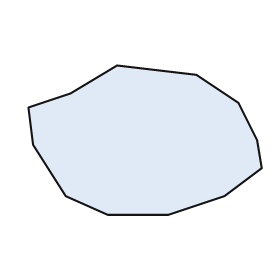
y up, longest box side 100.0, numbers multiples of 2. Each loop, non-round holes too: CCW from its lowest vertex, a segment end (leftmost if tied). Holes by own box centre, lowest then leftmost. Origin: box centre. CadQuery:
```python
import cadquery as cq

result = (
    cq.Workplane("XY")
    .moveTo(-16.0, -32.0)
    .lineTo(10.0, -32.0)
    .lineTo(34.0, -24.0)
    .lineTo(50.0, -12.0)
    .lineTo(48.0, 0.0)
    .lineTo(40.0, 16.0)
    .lineTo(22.0, 28.0)
    .lineTo(-12.0, 32.0)
    .lineTo(-32.0, 20.0)
    .lineTo(-50.0, 14.0)
    .lineTo(-48.0, -2.0)
    .lineTo(-34.0, -24.0)
    .close()
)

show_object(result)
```